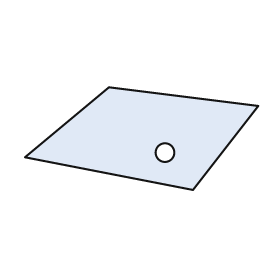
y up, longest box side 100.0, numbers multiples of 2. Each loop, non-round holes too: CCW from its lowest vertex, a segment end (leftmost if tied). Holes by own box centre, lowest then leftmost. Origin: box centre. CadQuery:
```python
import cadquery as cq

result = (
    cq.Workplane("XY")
    .moveTo(22.0, -22.0)
    .lineTo(50.0, 14.0)
    .lineTo(-14.0, 22.0)
    .lineTo(-50.0, -8.0)
    .close()
    .moveTo(10.0, -6.0)
    .circle(4.0)
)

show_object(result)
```